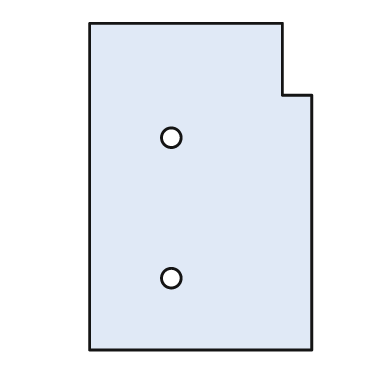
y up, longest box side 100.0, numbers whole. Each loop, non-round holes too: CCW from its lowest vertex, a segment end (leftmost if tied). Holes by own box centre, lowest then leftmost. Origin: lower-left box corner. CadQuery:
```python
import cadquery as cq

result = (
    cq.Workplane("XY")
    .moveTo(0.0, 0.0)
    .lineTo(68.0, 0.0)
    .lineTo(68.0, 78.0)
    .lineTo(59.0, 78.0)
    .lineTo(59.0, 100.0)
    .lineTo(0.0, 100.0)
    .close()
    .moveTo(25.0, 22.0)
    .circle(3.0)
    .moveTo(25.0, 65.0)
    .circle(3.0)
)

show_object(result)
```